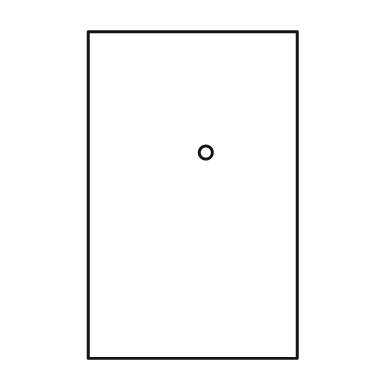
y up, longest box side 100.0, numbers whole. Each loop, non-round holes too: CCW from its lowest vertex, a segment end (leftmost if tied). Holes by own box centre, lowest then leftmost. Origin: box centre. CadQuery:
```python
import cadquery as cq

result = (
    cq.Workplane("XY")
    .moveTo(-32.0, -50.0)
    .lineTo(32.0, -50.0)
    .lineTo(32.0, 50.0)
    .lineTo(-32.0, 50.0)
    .close()
    .moveTo(4.0, 13.0)
    .circle(2.0)
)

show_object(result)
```